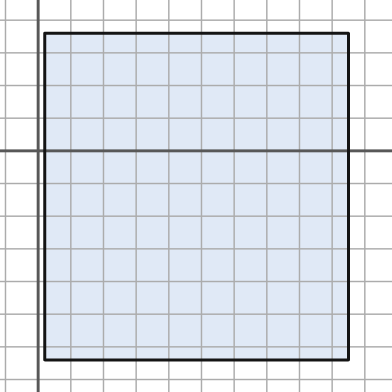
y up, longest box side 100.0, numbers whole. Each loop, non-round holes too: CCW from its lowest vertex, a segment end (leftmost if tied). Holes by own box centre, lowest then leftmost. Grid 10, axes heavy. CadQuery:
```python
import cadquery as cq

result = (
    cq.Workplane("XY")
    .moveTo(2.0, -64.0)
    .lineTo(95.0, -64.0)
    .lineTo(95.0, 36.0)
    .lineTo(2.0, 36.0)
    .close()
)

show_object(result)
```